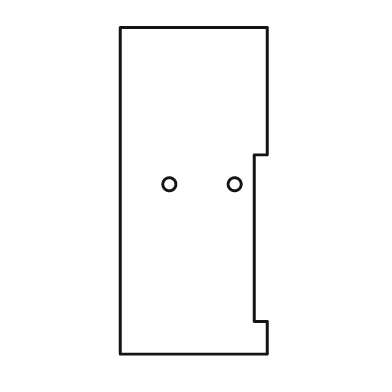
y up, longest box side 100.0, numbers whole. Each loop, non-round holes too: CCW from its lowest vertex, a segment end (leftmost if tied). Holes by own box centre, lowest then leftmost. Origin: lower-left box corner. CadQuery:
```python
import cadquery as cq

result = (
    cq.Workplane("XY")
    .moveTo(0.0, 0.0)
    .lineTo(45.0, 0.0)
    .lineTo(45.0, 10.0)
    .lineTo(41.0, 10.0)
    .lineTo(41.0, 61.0)
    .lineTo(45.0, 61.0)
    .lineTo(45.0, 100.0)
    .lineTo(0.0, 100.0)
    .close()
    .moveTo(15.0, 52.0)
    .circle(2.0)
    .moveTo(35.0, 52.0)
    .circle(2.0)
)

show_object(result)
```